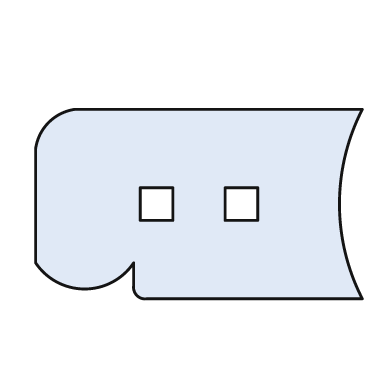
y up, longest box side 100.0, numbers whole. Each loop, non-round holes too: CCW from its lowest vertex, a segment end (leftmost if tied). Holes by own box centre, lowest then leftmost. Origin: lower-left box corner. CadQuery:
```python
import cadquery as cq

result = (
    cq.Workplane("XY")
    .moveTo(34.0, 0.0)
    .lineTo(100.0, 0.0)
    .threePointArc((93.0, 29.0), (100.0, 58.0))
    .lineTo(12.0, 58.0)
    .threePointArc((4.0, 54.0), (0.0, 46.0))
    .lineTo(0.0, 11.0)
    .threePointArc((15.0, 3.0), (30.0, 11.0))
    .lineTo(30.0, 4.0)
    .threePointArc((31.0, 1.0), (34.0, 0.0))
    .close()
    .moveTo(32.0, 24.0)
    .lineTo(42.0, 24.0)
    .lineTo(42.0, 34.0)
    .lineTo(32.0, 34.0)
    .close()
    .moveTo(58.0, 24.0)
    .lineTo(68.0, 24.0)
    .lineTo(68.0, 34.0)
    .lineTo(58.0, 34.0)
    .close()
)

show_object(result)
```